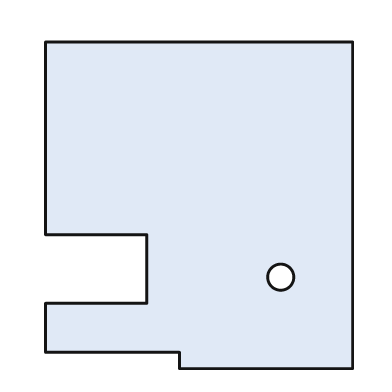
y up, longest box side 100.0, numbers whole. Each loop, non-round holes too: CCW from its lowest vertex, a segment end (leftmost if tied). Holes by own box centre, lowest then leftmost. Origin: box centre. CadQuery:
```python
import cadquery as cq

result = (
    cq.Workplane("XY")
    .moveTo(-6.0, -50.0)
    .lineTo(47.0, -50.0)
    .lineTo(47.0, 50.0)
    .lineTo(-47.0, 50.0)
    .lineTo(-47.0, -9.0)
    .lineTo(-16.0, -9.0)
    .lineTo(-16.0, -30.0)
    .lineTo(-47.0, -30.0)
    .lineTo(-47.0, -45.0)
    .lineTo(-6.0, -45.0)
    .close()
    .moveTo(25.0, -22.0)
    .circle(4.0)
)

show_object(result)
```